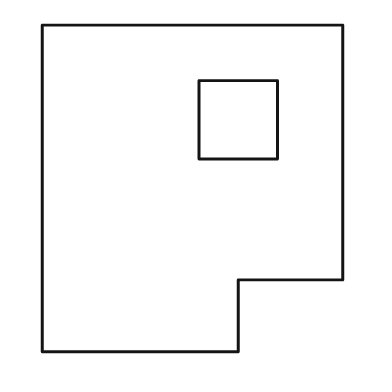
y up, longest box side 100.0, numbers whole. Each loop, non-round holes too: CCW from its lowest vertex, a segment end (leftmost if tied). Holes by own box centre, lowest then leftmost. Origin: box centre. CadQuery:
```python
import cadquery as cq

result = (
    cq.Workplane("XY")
    .moveTo(-46.0, -50.0)
    .lineTo(14.0, -50.0)
    .lineTo(14.0, -28.0)
    .lineTo(46.0, -28.0)
    .lineTo(46.0, 50.0)
    .lineTo(-46.0, 50.0)
    .close()
    .moveTo(2.0, 9.0)
    .lineTo(26.0, 9.0)
    .lineTo(26.0, 33.0)
    .lineTo(2.0, 33.0)
    .close()
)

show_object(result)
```